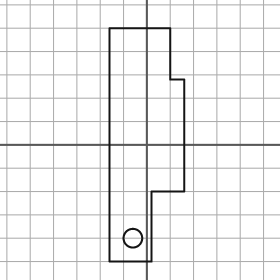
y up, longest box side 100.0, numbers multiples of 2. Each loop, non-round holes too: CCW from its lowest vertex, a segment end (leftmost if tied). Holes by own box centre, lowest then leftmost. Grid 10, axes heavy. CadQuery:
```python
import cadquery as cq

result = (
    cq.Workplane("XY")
    .moveTo(-16.0, -50.0)
    .lineTo(2.0, -50.0)
    .lineTo(2.0, -20.0)
    .lineTo(16.0, -20.0)
    .lineTo(16.0, 28.0)
    .lineTo(10.0, 28.0)
    .lineTo(10.0, 50.0)
    .lineTo(-16.0, 50.0)
    .close()
    .moveTo(-6.0, -40.0)
    .circle(4.0)
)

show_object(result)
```